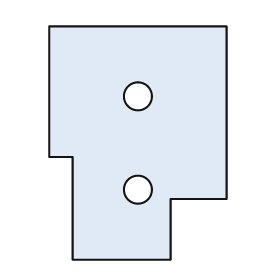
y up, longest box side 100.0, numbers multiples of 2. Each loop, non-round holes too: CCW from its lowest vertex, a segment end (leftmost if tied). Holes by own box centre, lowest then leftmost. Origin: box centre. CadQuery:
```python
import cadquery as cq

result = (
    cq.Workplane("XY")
    .moveTo(-28.0, -50.0)
    .lineTo(14.0, -50.0)
    .lineTo(14.0, -24.0)
    .lineTo(38.0, -24.0)
    .lineTo(38.0, 50.0)
    .lineTo(-38.0, 50.0)
    .lineTo(-38.0, -6.0)
    .lineTo(-28.0, -6.0)
    .close()
    .moveTo(0.0, -20.0)
    .circle(6.0)
    .moveTo(0.0, 20.0)
    .circle(6.0)
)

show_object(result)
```